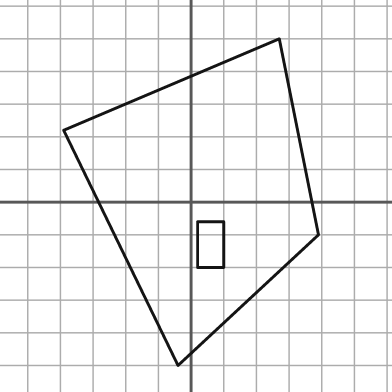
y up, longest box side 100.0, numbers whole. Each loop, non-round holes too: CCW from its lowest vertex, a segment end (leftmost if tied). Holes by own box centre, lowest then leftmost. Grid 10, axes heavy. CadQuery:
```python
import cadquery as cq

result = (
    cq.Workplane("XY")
    .moveTo(-4.0, -50.0)
    .lineTo(39.0, -10.0)
    .lineTo(27.0, 50.0)
    .lineTo(-39.0, 22.0)
    .close()
    .moveTo(2.0, -20.0)
    .lineTo(10.0, -20.0)
    .lineTo(10.0, -6.0)
    .lineTo(2.0, -6.0)
    .close()
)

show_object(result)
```